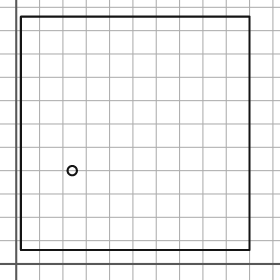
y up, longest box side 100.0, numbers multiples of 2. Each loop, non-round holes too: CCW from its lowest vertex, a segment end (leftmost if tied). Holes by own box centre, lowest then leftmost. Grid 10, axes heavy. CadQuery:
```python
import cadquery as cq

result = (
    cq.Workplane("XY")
    .moveTo(2.0, 6.0)
    .lineTo(100.0, 6.0)
    .lineTo(100.0, 106.0)
    .lineTo(2.0, 106.0)
    .close()
    .moveTo(24.0, 40.0)
    .circle(2.0)
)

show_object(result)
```